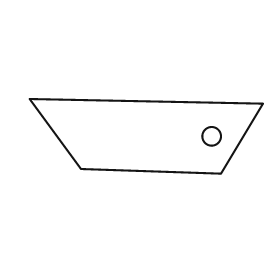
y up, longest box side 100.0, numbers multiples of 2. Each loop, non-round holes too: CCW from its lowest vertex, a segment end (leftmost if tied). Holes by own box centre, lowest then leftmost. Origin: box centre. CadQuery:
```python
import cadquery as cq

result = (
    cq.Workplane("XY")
    .moveTo(32.0, -16.0)
    .lineTo(50.0, 14.0)
    .lineTo(-50.0, 16.0)
    .lineTo(-28.0, -14.0)
    .close()
    .moveTo(28.0, 0.0)
    .circle(4.0)
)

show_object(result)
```